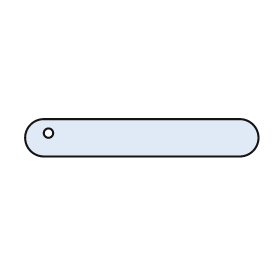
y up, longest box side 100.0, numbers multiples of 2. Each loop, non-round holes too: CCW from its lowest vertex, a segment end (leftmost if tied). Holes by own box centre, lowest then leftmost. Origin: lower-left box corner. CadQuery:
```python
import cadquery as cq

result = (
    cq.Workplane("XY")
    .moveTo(8.0, 0.0)
    .lineTo(92.0, 0.0)
    .threePointArc((100.0, 8.0), (92.0, 16.0))
    .lineTo(8.0, 16.0)
    .threePointArc((0.0, 8.0), (8.0, 0.0))
    .close()
    .moveTo(10.0, 10.0)
    .circle(2.0)
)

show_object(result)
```